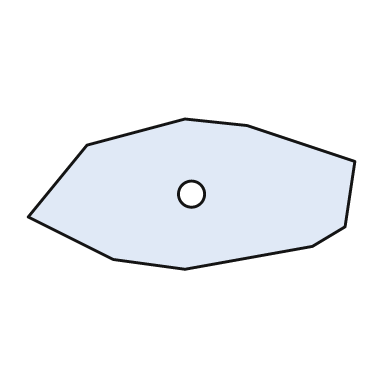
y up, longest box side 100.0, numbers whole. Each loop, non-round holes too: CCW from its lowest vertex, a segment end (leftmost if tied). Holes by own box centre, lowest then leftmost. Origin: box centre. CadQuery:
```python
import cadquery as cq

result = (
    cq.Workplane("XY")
    .moveTo(-2.0, -23.0)
    .lineTo(37.0, -16.0)
    .lineTo(47.0, -10.0)
    .lineTo(50.0, 10.0)
    .lineTo(17.0, 21.0)
    .lineTo(-2.0, 23.0)
    .lineTo(-32.0, 15.0)
    .lineTo(-50.0, -7.0)
    .lineTo(-24.0, -20.0)
    .close()
    .moveTo(0.0, 0.0)
    .circle(4.0)
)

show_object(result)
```